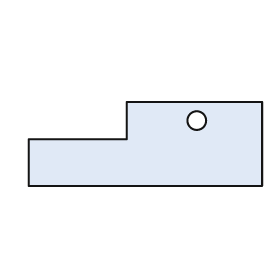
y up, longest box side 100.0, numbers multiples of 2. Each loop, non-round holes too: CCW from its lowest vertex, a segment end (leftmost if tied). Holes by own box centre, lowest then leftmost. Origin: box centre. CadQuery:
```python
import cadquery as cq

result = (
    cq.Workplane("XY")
    .moveTo(-50.0, -18.0)
    .lineTo(50.0, -18.0)
    .lineTo(50.0, 18.0)
    .lineTo(-8.0, 18.0)
    .lineTo(-8.0, 2.0)
    .lineTo(-50.0, 2.0)
    .close()
    .moveTo(22.0, 10.0)
    .circle(4.0)
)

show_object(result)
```